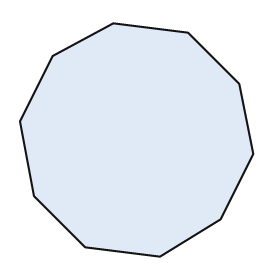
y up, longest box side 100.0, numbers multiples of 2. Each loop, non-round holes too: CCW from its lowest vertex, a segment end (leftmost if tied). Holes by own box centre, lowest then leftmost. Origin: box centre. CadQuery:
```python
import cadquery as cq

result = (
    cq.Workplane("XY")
    .moveTo(10.0, -50.0)
    .lineTo(36.0, -34.0)
    .lineTo(50.0, -6.0)
    .lineTo(44.0, 24.0)
    .lineTo(22.0, 46.0)
    .lineTo(-10.0, 50.0)
    .lineTo(-36.0, 36.0)
    .lineTo(-50.0, 8.0)
    .lineTo(-44.0, -24.0)
    .lineTo(-22.0, -46.0)
    .close()
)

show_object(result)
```